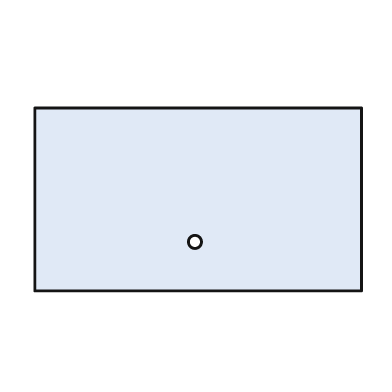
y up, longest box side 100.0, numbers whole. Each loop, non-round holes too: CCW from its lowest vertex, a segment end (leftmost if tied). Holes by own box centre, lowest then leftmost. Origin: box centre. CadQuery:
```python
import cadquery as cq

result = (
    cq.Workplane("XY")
    .moveTo(-50.0, -28.0)
    .lineTo(50.0, -28.0)
    .lineTo(50.0, 28.0)
    .lineTo(-50.0, 28.0)
    .close()
    .moveTo(-1.0, -13.0)
    .circle(2.0)
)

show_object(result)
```